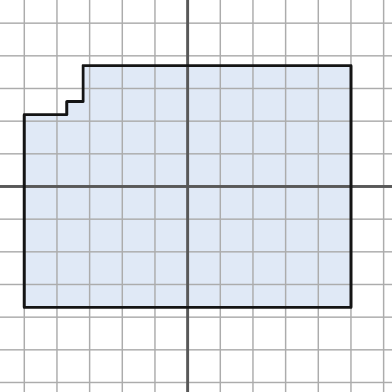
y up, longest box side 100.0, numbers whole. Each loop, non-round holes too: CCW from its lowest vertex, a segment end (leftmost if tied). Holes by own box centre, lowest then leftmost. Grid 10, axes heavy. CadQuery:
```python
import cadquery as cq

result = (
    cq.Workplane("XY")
    .moveTo(-50.0, -37.0)
    .lineTo(50.0, -37.0)
    .lineTo(50.0, 37.0)
    .lineTo(-32.0, 37.0)
    .lineTo(-32.0, 26.0)
    .lineTo(-37.0, 26.0)
    .lineTo(-37.0, 22.0)
    .lineTo(-50.0, 22.0)
    .close()
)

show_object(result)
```